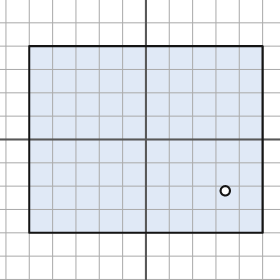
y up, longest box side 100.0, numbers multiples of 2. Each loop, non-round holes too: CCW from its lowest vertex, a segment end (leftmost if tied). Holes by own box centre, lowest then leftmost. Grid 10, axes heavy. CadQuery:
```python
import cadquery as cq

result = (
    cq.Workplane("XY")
    .moveTo(-50.0, -40.0)
    .lineTo(50.0, -40.0)
    .lineTo(50.0, 40.0)
    .lineTo(-50.0, 40.0)
    .close()
    .moveTo(34.0, -22.0)
    .circle(2.0)
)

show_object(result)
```